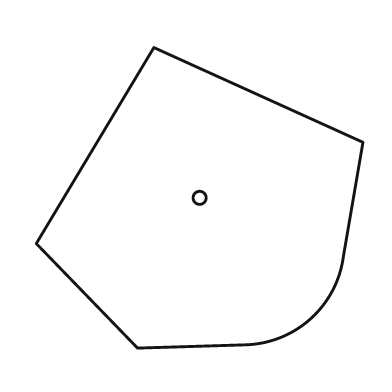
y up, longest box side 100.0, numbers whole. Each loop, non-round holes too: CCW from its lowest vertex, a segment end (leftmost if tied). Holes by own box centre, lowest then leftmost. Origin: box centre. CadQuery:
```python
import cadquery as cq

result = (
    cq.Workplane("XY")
    .moveTo(-19.0, -46.0)
    .lineTo(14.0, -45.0)
    .threePointArc((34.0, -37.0), (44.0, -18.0))
    .lineTo(50.0, 17.0)
    .lineTo(-14.0, 46.0)
    .lineTo(-50.0, -14.0)
    .close()
    .moveTo(0.0, 0.0)
    .circle(2.0)
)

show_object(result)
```